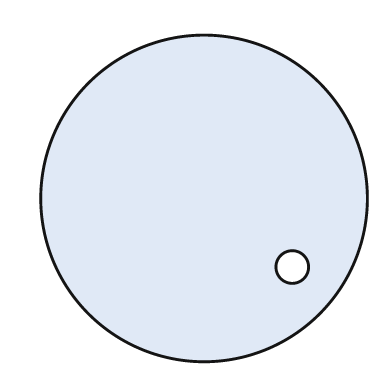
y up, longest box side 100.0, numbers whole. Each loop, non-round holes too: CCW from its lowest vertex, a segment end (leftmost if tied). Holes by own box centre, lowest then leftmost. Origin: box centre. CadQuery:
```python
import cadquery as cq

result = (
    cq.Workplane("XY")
    .moveTo(0.0, 0.0)
    .circle(50.0)
    .moveTo(27.0, -21.0)
    .circle(5.0)
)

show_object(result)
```